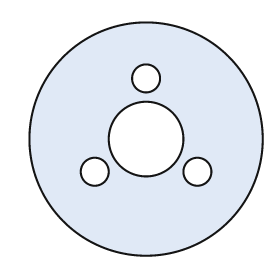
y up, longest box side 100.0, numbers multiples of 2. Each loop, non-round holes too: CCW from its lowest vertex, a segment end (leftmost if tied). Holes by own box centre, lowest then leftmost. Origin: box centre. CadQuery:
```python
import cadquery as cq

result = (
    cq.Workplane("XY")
    .moveTo(0.0, 0.0)
    .circle(50.0)
    .moveTo(-22.0, -14.0)
    .circle(6.0)
    .moveTo(22.0, -14.0)
    .circle(6.0)
    .moveTo(0.0, 0.0)
    .circle(16.0)
    .moveTo(0.0, 26.0)
    .circle(6.0)
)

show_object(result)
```